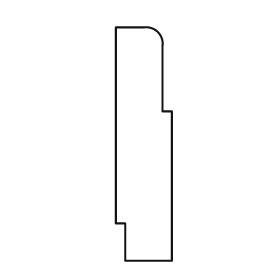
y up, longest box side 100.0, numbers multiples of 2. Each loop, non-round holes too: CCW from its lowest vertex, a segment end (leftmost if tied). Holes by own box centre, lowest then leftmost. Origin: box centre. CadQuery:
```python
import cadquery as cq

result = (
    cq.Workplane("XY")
    .moveTo(-8.0, -50.0)
    .lineTo(12.0, -50.0)
    .lineTo(12.0, 14.0)
    .lineTo(8.0, 14.0)
    .lineTo(8.0, 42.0)
    .threePointArc((6.0, 48.0), (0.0, 50.0))
    .lineTo(-12.0, 50.0)
    .lineTo(-12.0, -34.0)
    .lineTo(-8.0, -34.0)
    .close()
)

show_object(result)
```